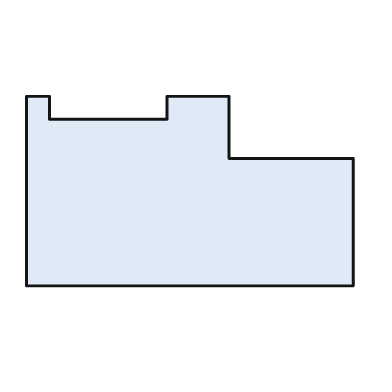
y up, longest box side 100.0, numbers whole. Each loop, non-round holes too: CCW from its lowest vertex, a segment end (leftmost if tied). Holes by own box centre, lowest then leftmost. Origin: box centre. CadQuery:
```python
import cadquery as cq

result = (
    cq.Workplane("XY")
    .moveTo(-50.0, -29.0)
    .lineTo(50.0, -29.0)
    .lineTo(50.0, 10.0)
    .lineTo(12.0, 10.0)
    .lineTo(12.0, 29.0)
    .lineTo(-7.0, 29.0)
    .lineTo(-7.0, 22.0)
    .lineTo(-43.0, 22.0)
    .lineTo(-43.0, 29.0)
    .lineTo(-50.0, 29.0)
    .close()
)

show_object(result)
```